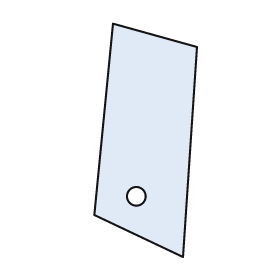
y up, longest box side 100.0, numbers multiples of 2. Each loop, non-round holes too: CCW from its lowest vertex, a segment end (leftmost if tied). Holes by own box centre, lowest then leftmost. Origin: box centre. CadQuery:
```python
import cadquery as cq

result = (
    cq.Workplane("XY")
    .moveTo(16.0, -50.0)
    .lineTo(22.0, 40.0)
    .lineTo(-14.0, 50.0)
    .lineTo(-22.0, -32.0)
    .close()
    .moveTo(-4.0, -24.0)
    .circle(4.0)
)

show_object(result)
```